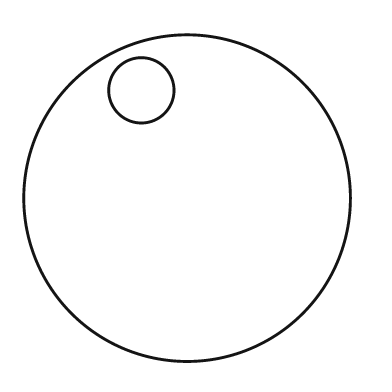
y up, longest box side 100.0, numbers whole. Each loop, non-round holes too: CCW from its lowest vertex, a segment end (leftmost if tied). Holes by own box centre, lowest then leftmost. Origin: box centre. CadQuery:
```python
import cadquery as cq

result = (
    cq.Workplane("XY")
    .moveTo(0.0, 0.0)
    .circle(50.0)
    .moveTo(-14.0, 33.0)
    .circle(10.0)
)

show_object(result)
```